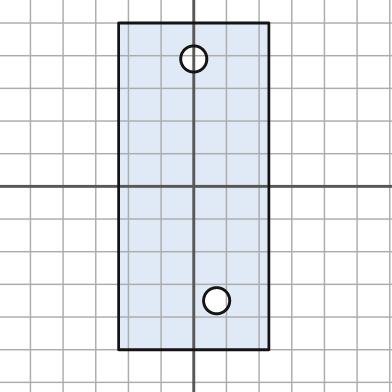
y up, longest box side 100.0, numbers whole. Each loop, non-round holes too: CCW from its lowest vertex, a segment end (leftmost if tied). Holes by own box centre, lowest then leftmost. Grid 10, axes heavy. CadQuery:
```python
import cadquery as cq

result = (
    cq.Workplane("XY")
    .moveTo(-23.0, -50.0)
    .lineTo(23.0, -50.0)
    .lineTo(23.0, 50.0)
    .lineTo(-23.0, 50.0)
    .close()
    .moveTo(7.0, -35.0)
    .circle(4.0)
    .moveTo(0.0, 39.0)
    .circle(4.0)
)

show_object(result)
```